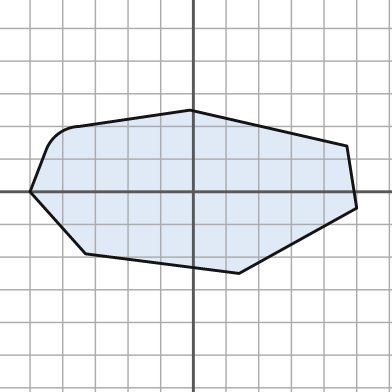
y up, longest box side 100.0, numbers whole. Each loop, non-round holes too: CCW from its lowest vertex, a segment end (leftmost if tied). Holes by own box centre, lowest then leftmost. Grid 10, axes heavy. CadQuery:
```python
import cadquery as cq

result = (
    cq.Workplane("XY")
    .moveTo(14.0, -25.0)
    .lineTo(50.0, -5.0)
    .lineTo(47.0, 14.0)
    .lineTo(-1.0, 25.0)
    .lineTo(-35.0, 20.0)
    .threePointArc((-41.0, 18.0), (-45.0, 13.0))
    .lineTo(-50.0, 0.0)
    .lineTo(-33.0, -19.0)
    .close()
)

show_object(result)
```